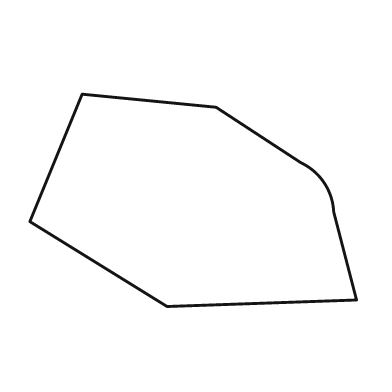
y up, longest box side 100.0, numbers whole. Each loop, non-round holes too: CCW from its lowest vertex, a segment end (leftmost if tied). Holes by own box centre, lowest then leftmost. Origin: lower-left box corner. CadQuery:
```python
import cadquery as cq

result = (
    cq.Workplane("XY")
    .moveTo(42.0, 0.0)
    .lineTo(100.0, 2.0)
    .lineTo(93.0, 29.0)
    .threePointArc((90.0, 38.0), (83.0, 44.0))
    .lineTo(57.0, 61.0)
    .lineTo(16.0, 65.0)
    .lineTo(0.0, 26.0)
    .close()
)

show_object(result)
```